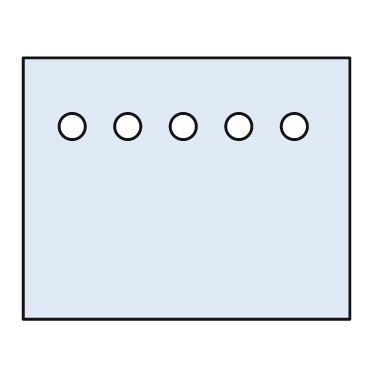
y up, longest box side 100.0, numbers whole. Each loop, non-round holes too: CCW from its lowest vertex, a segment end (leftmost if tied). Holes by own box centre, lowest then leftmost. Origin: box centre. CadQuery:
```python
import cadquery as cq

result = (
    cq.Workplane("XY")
    .moveTo(-50.0, -40.0)
    .lineTo(50.0, -40.0)
    .lineTo(50.0, 40.0)
    .lineTo(-50.0, 40.0)
    .close()
    .moveTo(-35.0, 19.0)
    .circle(4.0)
    .moveTo(-18.0, 19.0)
    .circle(4.0)
    .moveTo(-1.0, 19.0)
    .circle(4.0)
    .moveTo(16.0, 19.0)
    .circle(4.0)
    .moveTo(33.0, 19.0)
    .circle(4.0)
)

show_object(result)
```